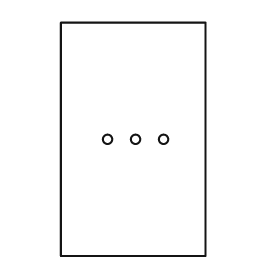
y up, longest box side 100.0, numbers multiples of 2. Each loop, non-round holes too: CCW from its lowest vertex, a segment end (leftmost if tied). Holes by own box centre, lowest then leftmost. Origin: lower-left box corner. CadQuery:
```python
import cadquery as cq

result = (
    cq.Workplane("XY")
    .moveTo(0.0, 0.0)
    .lineTo(62.0, 0.0)
    .lineTo(62.0, 100.0)
    .lineTo(0.0, 100.0)
    .close()
    .moveTo(20.0, 50.0)
    .circle(2.0)
    .moveTo(32.0, 50.0)
    .circle(2.0)
    .moveTo(44.0, 50.0)
    .circle(2.0)
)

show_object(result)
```